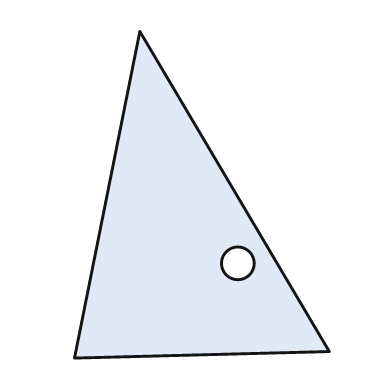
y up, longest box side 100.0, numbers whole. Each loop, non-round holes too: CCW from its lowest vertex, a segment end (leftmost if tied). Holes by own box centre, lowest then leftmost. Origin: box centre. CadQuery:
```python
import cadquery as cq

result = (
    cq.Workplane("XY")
    .moveTo(-39.0, -50.0)
    .lineTo(39.0, -48.0)
    .lineTo(-19.0, 50.0)
    .close()
    .moveTo(11.0, -21.0)
    .circle(5.0)
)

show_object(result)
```